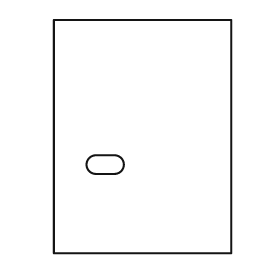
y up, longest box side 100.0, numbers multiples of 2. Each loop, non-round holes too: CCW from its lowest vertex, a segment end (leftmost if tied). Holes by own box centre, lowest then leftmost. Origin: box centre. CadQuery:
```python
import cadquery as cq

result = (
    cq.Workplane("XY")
    .moveTo(-38.0, -50.0)
    .lineTo(38.0, -50.0)
    .lineTo(38.0, 50.0)
    .lineTo(-38.0, 50.0)
    .close()
    .moveTo(-20.0, -16.0)
    .lineTo(-12.0, -16.0)
    .threePointArc((-8.0, -12.0), (-12.0, -8.0))
    .lineTo(-20.0, -8.0)
    .threePointArc((-24.0, -12.0), (-20.0, -16.0))
    .close()
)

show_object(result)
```